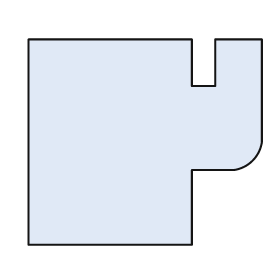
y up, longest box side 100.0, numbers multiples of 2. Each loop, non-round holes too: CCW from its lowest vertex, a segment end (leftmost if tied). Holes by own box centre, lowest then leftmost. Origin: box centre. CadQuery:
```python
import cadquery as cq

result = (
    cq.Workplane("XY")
    .moveTo(-50.0, -44.0)
    .lineTo(20.0, -44.0)
    .lineTo(20.0, -12.0)
    .lineTo(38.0, -12.0)
    .threePointArc((46.0, -8.0), (50.0, 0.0))
    .lineTo(50.0, 44.0)
    .lineTo(30.0, 44.0)
    .lineTo(30.0, 24.0)
    .lineTo(20.0, 24.0)
    .lineTo(20.0, 44.0)
    .lineTo(-50.0, 44.0)
    .close()
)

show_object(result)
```